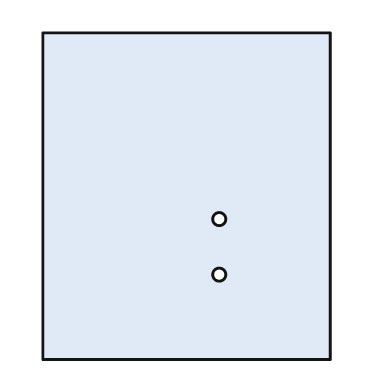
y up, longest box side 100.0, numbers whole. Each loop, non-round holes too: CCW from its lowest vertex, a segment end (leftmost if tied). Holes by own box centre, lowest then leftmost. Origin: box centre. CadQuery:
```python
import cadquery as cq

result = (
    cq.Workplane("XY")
    .moveTo(-44.0, -50.0)
    .lineTo(44.0, -50.0)
    .lineTo(44.0, 50.0)
    .lineTo(-44.0, 50.0)
    .close()
    .moveTo(10.0, -24.0)
    .circle(2.0)
    .moveTo(10.0, -7.0)
    .circle(2.0)
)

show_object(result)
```